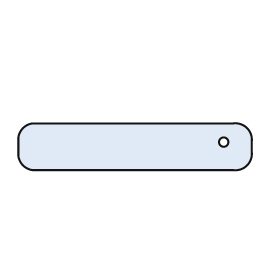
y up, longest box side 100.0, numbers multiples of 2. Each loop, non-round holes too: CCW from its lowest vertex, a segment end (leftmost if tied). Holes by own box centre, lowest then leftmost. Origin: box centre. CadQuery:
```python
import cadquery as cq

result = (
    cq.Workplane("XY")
    .moveTo(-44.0, -10.0)
    .lineTo(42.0, -10.0)
    .threePointArc((48.0, -8.0), (50.0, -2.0))
    .lineTo(50.0, 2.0)
    .threePointArc((48.0, 8.0), (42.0, 10.0))
    .lineTo(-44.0, 10.0)
    .threePointArc((-48.0, 8.0), (-50.0, 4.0))
    .lineTo(-50.0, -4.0)
    .threePointArc((-48.0, -8.0), (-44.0, -10.0))
    .close()
    .moveTo(38.0, 2.0)
    .circle(2.0)
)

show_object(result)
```